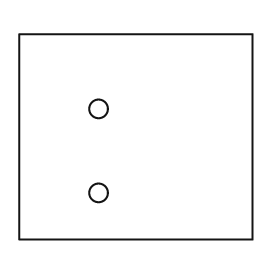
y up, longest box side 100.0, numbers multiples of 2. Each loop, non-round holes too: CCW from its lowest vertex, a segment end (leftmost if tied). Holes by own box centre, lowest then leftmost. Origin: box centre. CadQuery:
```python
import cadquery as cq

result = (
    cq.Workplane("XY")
    .moveTo(-50.0, -44.0)
    .lineTo(50.0, -44.0)
    .lineTo(50.0, 44.0)
    .lineTo(-50.0, 44.0)
    .close()
    .moveTo(-16.0, -24.0)
    .circle(4.0)
    .moveTo(-16.0, 12.0)
    .circle(4.0)
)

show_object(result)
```